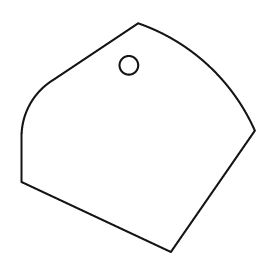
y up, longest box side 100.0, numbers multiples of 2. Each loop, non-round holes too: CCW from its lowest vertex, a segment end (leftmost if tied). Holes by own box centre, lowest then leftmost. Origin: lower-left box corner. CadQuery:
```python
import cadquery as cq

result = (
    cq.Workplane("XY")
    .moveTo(64.0, 0.0)
    .lineTo(100.0, 52.0)
    .threePointArc((80.0, 80.0), (50.0, 98.0))
    .lineTo(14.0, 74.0)
    .threePointArc((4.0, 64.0), (0.0, 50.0))
    .lineTo(0.0, 30.0)
    .close()
    .moveTo(46.0, 80.0)
    .circle(4.0)
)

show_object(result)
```